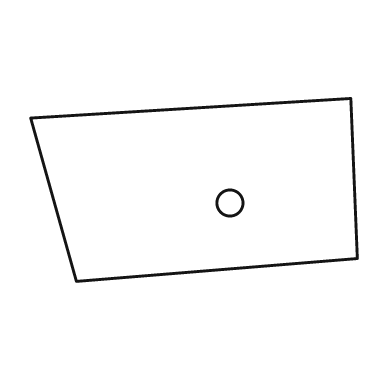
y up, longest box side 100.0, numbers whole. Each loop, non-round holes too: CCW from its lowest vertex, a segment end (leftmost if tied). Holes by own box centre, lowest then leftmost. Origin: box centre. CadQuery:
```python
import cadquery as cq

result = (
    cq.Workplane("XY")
    .moveTo(-36.0, -28.0)
    .lineTo(50.0, -21.0)
    .lineTo(48.0, 28.0)
    .lineTo(-50.0, 22.0)
    .close()
    .moveTo(11.0, -4.0)
    .circle(4.0)
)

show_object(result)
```